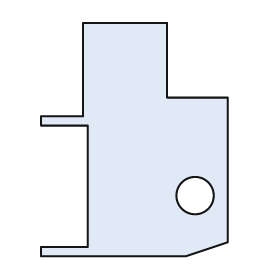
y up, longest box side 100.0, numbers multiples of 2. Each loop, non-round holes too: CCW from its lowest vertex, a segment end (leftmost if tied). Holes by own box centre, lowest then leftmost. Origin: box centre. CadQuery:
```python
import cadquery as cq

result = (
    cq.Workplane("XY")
    .moveTo(-40.0, -50.0)
    .lineTo(22.0, -50.0)
    .lineTo(40.0, -44.0)
    .lineTo(40.0, 18.0)
    .lineTo(14.0, 18.0)
    .lineTo(14.0, 50.0)
    .lineTo(-22.0, 50.0)
    .lineTo(-22.0, 10.0)
    .lineTo(-40.0, 10.0)
    .lineTo(-40.0, 6.0)
    .lineTo(-20.0, 6.0)
    .lineTo(-20.0, -46.0)
    .lineTo(-40.0, -46.0)
    .close()
    .moveTo(26.0, -24.0)
    .circle(8.0)
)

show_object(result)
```